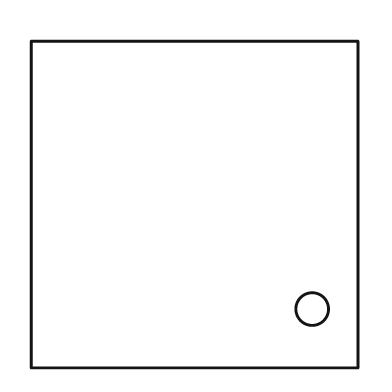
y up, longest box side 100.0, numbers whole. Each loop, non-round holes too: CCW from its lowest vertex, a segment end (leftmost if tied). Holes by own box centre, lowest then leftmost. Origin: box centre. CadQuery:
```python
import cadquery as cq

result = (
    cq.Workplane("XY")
    .moveTo(-50.0, -50.0)
    .lineTo(50.0, -50.0)
    .lineTo(50.0, 50.0)
    .lineTo(-50.0, 50.0)
    .close()
    .moveTo(36.0, -32.0)
    .circle(5.0)
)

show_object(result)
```